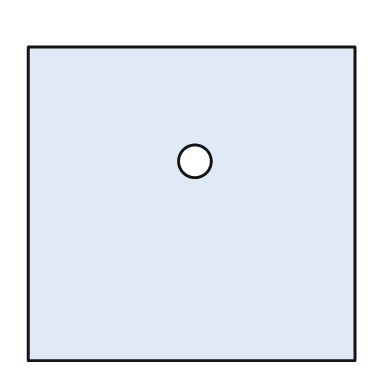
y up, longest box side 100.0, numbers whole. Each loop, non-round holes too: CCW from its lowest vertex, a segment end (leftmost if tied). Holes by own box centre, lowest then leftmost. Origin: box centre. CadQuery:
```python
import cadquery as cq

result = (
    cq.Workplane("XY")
    .moveTo(-50.0, -48.0)
    .lineTo(50.0, -48.0)
    .lineTo(50.0, 48.0)
    .lineTo(-50.0, 48.0)
    .close()
    .moveTo(1.0, 13.0)
    .circle(5.0)
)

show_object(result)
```